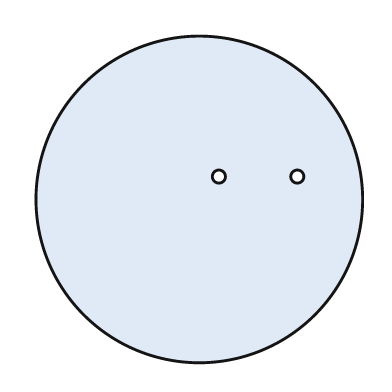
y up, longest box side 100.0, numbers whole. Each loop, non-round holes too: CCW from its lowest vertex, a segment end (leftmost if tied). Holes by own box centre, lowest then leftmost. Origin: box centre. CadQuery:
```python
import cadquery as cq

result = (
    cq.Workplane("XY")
    .moveTo(0.0, 0.0)
    .circle(50.0)
    .moveTo(6.0, 7.0)
    .circle(2.0)
    .moveTo(30.0, 7.0)
    .circle(2.0)
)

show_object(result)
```